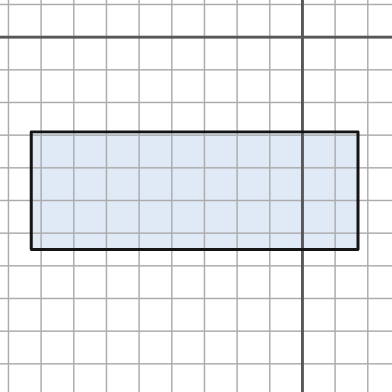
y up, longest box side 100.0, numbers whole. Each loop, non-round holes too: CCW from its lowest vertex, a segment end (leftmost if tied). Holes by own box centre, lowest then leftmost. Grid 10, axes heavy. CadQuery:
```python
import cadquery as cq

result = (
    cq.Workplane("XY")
    .moveTo(-83.0, -65.0)
    .lineTo(17.0, -65.0)
    .lineTo(17.0, -29.0)
    .lineTo(-83.0, -29.0)
    .close()
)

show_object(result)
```